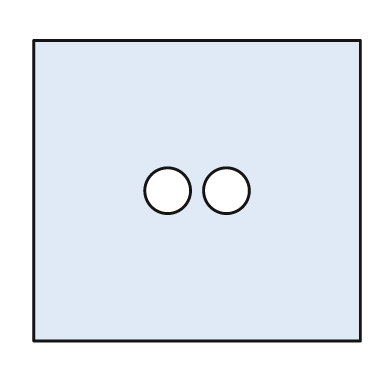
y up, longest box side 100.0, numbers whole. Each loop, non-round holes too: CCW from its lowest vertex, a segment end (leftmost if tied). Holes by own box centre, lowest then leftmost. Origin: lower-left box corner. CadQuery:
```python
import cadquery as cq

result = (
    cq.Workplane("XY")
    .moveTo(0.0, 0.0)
    .lineTo(100.0, 0.0)
    .lineTo(100.0, 92.0)
    .lineTo(0.0, 92.0)
    .close()
    .moveTo(41.0, 46.0)
    .circle(7.0)
    .moveTo(59.0, 46.0)
    .circle(7.0)
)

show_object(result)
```